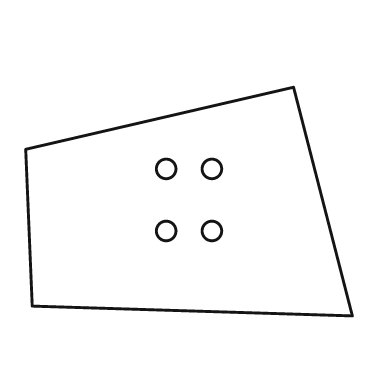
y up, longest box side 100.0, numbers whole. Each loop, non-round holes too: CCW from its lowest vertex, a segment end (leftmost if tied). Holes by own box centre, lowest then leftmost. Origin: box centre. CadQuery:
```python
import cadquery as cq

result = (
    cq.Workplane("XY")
    .moveTo(50.0, -35.0)
    .lineTo(32.0, 35.0)
    .lineTo(-50.0, 16.0)
    .lineTo(-48.0, -32.0)
    .close()
    .moveTo(-7.0, -9.0)
    .circle(3.0)
    .moveTo(7.0, -9.0)
    .circle(3.0)
    .moveTo(-7.0, 10.0)
    .circle(3.0)
    .moveTo(7.0, 10.0)
    .circle(3.0)
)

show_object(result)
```